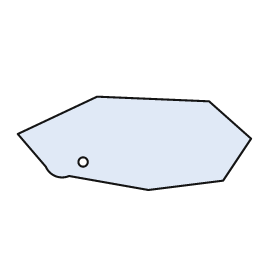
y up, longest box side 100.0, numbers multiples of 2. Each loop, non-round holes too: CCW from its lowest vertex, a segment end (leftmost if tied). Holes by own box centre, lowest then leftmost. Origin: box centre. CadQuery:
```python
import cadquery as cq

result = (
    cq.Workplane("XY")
    .moveTo(6.0, -20.0)
    .lineTo(38.0, -16.0)
    .lineTo(50.0, 2.0)
    .lineTo(32.0, 18.0)
    .lineTo(-16.0, 20.0)
    .lineTo(-50.0, 4.0)
    .lineTo(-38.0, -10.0)
    .threePointArc((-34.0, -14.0), (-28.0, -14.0))
    .close()
    .moveTo(-22.0, -8.0)
    .circle(2.0)
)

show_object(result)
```